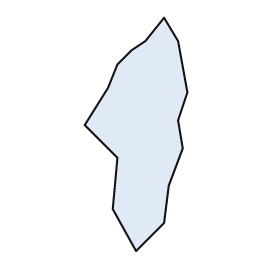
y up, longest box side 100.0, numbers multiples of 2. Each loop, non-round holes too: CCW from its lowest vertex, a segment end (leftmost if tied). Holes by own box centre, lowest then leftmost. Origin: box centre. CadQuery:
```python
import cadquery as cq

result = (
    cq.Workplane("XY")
    .moveTo(0.0, -50.0)
    .lineTo(12.0, -38.0)
    .lineTo(14.0, -22.0)
    .lineTo(20.0, -6.0)
    .lineTo(18.0, 6.0)
    .lineTo(22.0, 18.0)
    .lineTo(18.0, 40.0)
    .lineTo(12.0, 50.0)
    .lineTo(4.0, 40.0)
    .lineTo(-2.0, 36.0)
    .lineTo(-8.0, 30.0)
    .lineTo(-12.0, 20.0)
    .lineTo(-22.0, 4.0)
    .lineTo(-8.0, -10.0)
    .lineTo(-10.0, -32.0)
    .close()
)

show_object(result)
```